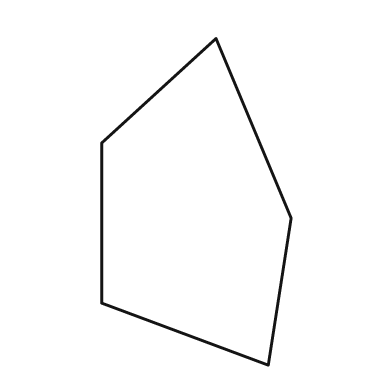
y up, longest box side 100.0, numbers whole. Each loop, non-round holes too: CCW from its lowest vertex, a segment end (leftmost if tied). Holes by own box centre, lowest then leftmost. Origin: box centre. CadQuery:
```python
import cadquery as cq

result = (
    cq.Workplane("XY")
    .moveTo(22.0, -50.0)
    .lineTo(29.0, -5.0)
    .lineTo(6.0, 50.0)
    .lineTo(-29.0, 18.0)
    .lineTo(-29.0, -31.0)
    .close()
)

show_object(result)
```